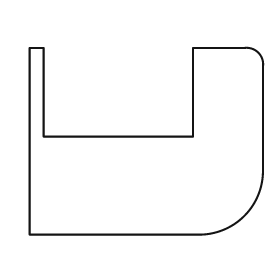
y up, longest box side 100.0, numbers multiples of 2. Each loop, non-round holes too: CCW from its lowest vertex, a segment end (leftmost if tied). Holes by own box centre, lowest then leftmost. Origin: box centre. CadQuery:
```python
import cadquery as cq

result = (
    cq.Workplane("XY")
    .moveTo(-50.0, -40.0)
    .lineTo(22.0, -40.0)
    .threePointArc((42.0, -32.0), (50.0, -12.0))
    .lineTo(50.0, 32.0)
    .threePointArc((48.0, 38.0), (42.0, 40.0))
    .lineTo(20.0, 40.0)
    .lineTo(20.0, 2.0)
    .lineTo(-44.0, 2.0)
    .lineTo(-44.0, 40.0)
    .lineTo(-50.0, 40.0)
    .close()
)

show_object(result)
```